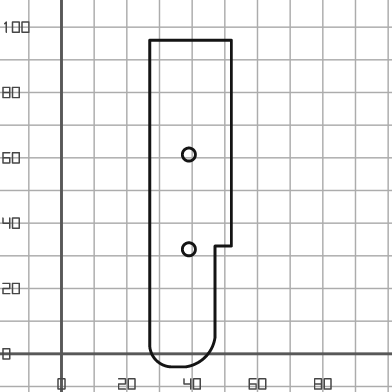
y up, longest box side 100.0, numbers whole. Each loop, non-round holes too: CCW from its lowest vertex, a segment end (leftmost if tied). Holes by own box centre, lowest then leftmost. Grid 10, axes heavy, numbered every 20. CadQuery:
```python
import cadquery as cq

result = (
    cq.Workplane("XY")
    .moveTo(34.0, -4.0)
    .lineTo(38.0, -4.0)
    .threePointArc((44.0, -1.0), (47.0, 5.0))
    .lineTo(47.0, 33.0)
    .lineTo(52.0, 33.0)
    .lineTo(52.0, 96.0)
    .lineTo(27.0, 96.0)
    .lineTo(27.0, 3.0)
    .threePointArc((29.0, -2.0), (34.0, -4.0))
    .close()
    .moveTo(39.0, 32.0)
    .circle(2.0)
    .moveTo(39.0, 61.0)
    .circle(2.0)
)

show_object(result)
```